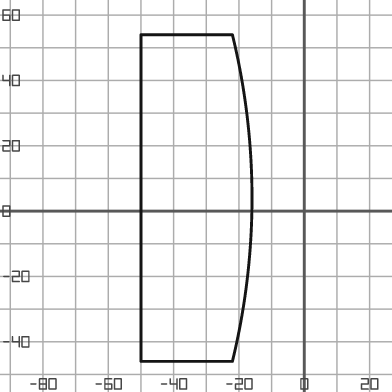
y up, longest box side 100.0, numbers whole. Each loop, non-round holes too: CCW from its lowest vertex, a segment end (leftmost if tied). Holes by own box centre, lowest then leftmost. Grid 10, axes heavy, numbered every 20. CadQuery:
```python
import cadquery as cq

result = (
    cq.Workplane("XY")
    .moveTo(-50.0, -46.0)
    .lineTo(-22.0, -46.0)
    .threePointArc((-16.0, 4.0), (-22.0, 54.0))
    .lineTo(-50.0, 54.0)
    .close()
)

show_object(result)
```